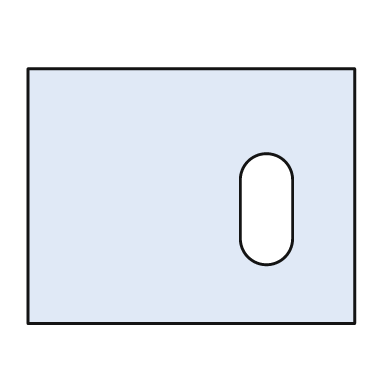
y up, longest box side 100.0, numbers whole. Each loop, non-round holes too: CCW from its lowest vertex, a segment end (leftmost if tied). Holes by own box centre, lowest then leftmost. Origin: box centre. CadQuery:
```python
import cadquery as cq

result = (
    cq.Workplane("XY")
    .moveTo(-50.0, -39.0)
    .lineTo(50.0, -39.0)
    .lineTo(50.0, 39.0)
    .lineTo(-50.0, 39.0)
    .close()
    .moveTo(15.0, -13.0)
    .threePointArc((23.0, -21.0), (31.0, -13.0))
    .lineTo(31.0, 5.0)
    .threePointArc((23.0, 13.0), (15.0, 5.0))
    .close()
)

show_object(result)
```